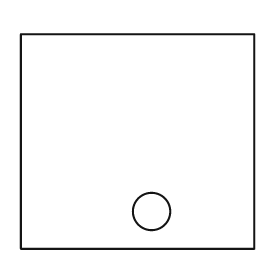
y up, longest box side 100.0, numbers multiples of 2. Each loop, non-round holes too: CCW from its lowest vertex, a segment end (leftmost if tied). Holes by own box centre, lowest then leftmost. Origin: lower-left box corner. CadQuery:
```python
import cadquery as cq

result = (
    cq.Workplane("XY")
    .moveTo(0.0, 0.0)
    .lineTo(100.0, 0.0)
    .lineTo(100.0, 92.0)
    .lineTo(0.0, 92.0)
    .close()
    .moveTo(56.0, 16.0)
    .circle(8.0)
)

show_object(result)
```